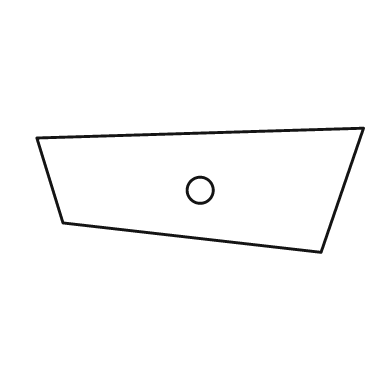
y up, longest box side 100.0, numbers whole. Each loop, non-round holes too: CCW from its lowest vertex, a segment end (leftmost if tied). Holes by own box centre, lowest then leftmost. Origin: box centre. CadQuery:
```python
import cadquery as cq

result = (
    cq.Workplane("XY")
    .moveTo(37.0, -19.0)
    .lineTo(50.0, 19.0)
    .lineTo(-50.0, 16.0)
    .lineTo(-42.0, -10.0)
    .close()
    .moveTo(0.0, 0.0)
    .circle(4.0)
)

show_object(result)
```